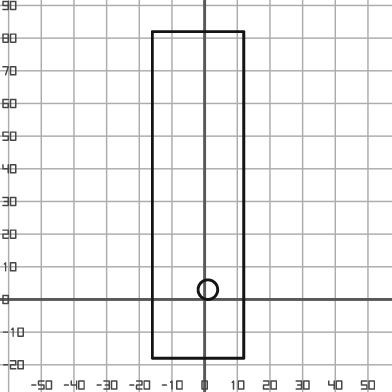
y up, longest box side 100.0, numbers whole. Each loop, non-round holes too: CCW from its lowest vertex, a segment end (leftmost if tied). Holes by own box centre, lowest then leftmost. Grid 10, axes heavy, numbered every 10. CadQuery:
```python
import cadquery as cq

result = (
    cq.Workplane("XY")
    .moveTo(-16.0, -18.0)
    .lineTo(12.0, -18.0)
    .lineTo(12.0, 82.0)
    .lineTo(-16.0, 82.0)
    .close()
    .moveTo(1.0, 3.0)
    .circle(3.0)
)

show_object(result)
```